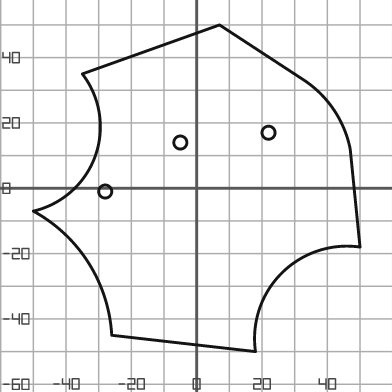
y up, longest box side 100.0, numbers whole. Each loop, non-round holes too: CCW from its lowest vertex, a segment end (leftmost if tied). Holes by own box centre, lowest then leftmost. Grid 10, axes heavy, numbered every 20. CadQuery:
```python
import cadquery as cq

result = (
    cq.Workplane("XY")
    .moveTo(18.0, -50.0)
    .threePointArc((26.0, -26.0), (50.0, -18.0))
    .lineTo(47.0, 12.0)
    .threePointArc((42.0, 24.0), (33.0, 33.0))
    .lineTo(7.0, 50.0)
    .lineTo(-35.0, 35.0)
    .threePointArc((-31.0, 10.0), (-50.0, -7.0))
    .threePointArc((-33.0, -23.0), (-26.0, -45.0))
    .close()
    .moveTo(-28.0, -1.0)
    .circle(2.0)
    .moveTo(-5.0, 14.0)
    .circle(2.0)
    .moveTo(22.0, 17.0)
    .circle(2.0)
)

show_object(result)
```